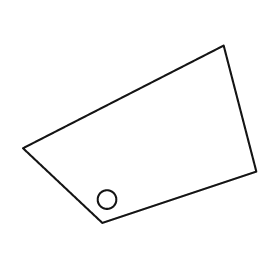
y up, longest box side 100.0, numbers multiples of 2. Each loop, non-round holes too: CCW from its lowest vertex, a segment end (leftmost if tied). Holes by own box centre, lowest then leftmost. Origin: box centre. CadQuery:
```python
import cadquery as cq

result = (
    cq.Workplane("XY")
    .moveTo(-16.0, -38.0)
    .lineTo(50.0, -16.0)
    .lineTo(36.0, 38.0)
    .lineTo(-50.0, -6.0)
    .close()
    .moveTo(-14.0, -28.0)
    .circle(4.0)
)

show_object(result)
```